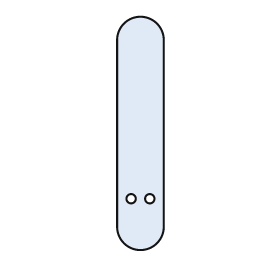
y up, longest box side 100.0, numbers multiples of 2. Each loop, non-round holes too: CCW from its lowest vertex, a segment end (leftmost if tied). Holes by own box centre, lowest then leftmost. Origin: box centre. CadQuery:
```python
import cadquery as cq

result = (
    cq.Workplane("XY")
    .moveTo(-10.0, -40.0)
    .threePointArc((0.0, -50.0), (10.0, -40.0))
    .lineTo(10.0, 40.0)
    .threePointArc((0.0, 50.0), (-10.0, 40.0))
    .close()
    .moveTo(-4.0, -28.0)
    .circle(2.0)
    .moveTo(4.0, -28.0)
    .circle(2.0)
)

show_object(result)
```